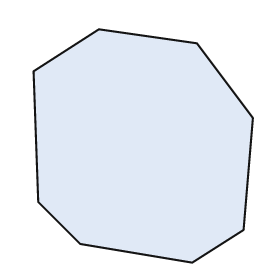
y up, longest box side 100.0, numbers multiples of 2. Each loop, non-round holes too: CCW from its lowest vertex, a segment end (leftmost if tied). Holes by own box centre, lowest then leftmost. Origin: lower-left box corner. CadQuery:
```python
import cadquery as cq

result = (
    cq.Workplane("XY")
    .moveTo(68.0, 0.0)
    .lineTo(90.0, 14.0)
    .lineTo(94.0, 62.0)
    .lineTo(70.0, 94.0)
    .lineTo(28.0, 100.0)
    .lineTo(0.0, 82.0)
    .lineTo(2.0, 26.0)
    .lineTo(20.0, 8.0)
    .close()
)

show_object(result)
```